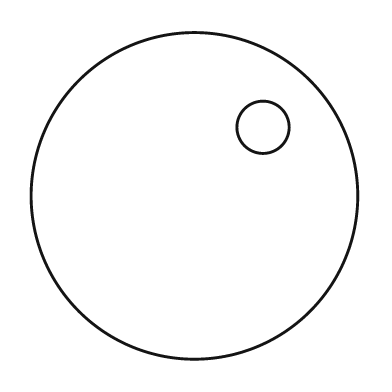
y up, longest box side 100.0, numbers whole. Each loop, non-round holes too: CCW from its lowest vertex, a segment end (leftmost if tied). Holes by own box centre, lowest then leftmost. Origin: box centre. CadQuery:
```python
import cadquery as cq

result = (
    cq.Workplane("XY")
    .moveTo(0.0, 0.0)
    .circle(50.0)
    .moveTo(21.0, 21.0)
    .circle(8.0)
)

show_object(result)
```